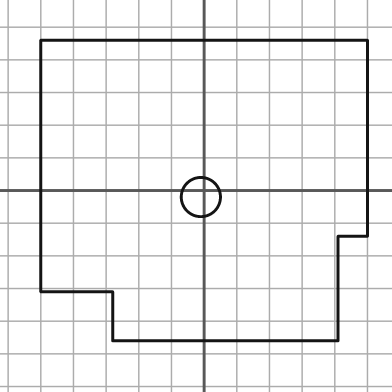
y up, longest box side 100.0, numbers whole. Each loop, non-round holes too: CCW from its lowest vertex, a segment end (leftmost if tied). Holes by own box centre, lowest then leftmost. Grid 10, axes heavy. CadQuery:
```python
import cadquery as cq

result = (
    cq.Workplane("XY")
    .moveTo(-28.0, -46.0)
    .lineTo(41.0, -46.0)
    .lineTo(41.0, -14.0)
    .lineTo(50.0, -14.0)
    .lineTo(50.0, 46.0)
    .lineTo(-50.0, 46.0)
    .lineTo(-50.0, -31.0)
    .lineTo(-28.0, -31.0)
    .close()
    .moveTo(-1.0, -2.0)
    .circle(6.0)
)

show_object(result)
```